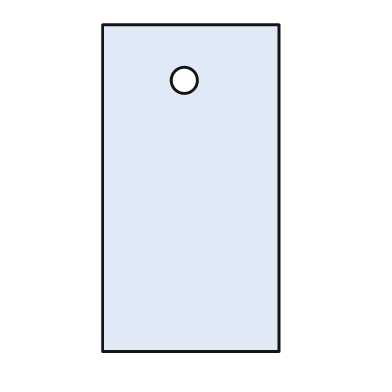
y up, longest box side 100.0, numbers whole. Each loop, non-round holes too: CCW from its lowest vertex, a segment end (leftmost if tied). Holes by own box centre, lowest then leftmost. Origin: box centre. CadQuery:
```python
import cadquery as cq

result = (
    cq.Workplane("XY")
    .moveTo(-27.0, -50.0)
    .lineTo(27.0, -50.0)
    .lineTo(27.0, 50.0)
    .lineTo(-27.0, 50.0)
    .close()
    .moveTo(-2.0, 33.0)
    .circle(4.0)
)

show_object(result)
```